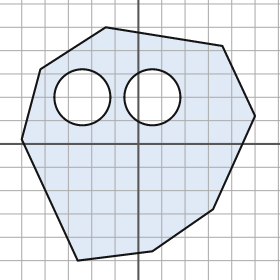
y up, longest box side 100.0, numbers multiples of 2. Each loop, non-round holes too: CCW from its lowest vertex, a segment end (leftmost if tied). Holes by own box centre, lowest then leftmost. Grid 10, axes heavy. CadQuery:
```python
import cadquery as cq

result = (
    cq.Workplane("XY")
    .moveTo(-26.0, -50.0)
    .lineTo(6.0, -46.0)
    .lineTo(32.0, -28.0)
    .lineTo(50.0, 12.0)
    .lineTo(36.0, 42.0)
    .lineTo(-14.0, 50.0)
    .lineTo(-42.0, 32.0)
    .lineTo(-50.0, 2.0)
    .close()
    .moveTo(-24.0, 20.0)
    .circle(12.0)
    .moveTo(6.0, 20.0)
    .circle(12.0)
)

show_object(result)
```